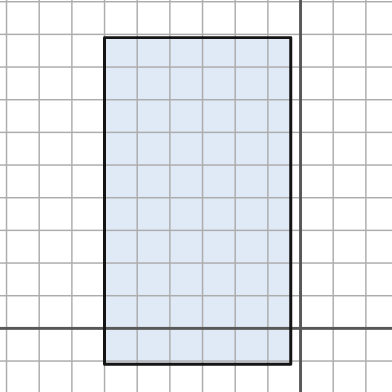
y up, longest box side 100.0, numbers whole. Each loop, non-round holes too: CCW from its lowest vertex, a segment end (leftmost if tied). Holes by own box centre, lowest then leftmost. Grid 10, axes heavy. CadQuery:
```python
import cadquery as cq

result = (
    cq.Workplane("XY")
    .moveTo(-60.0, -11.0)
    .lineTo(-3.0, -11.0)
    .lineTo(-3.0, 89.0)
    .lineTo(-60.0, 89.0)
    .close()
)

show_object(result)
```